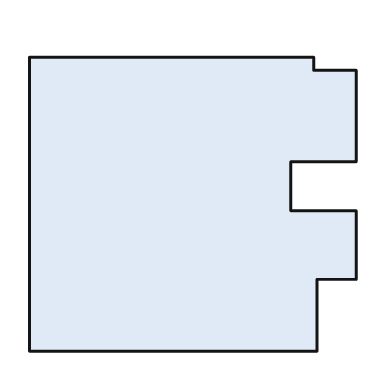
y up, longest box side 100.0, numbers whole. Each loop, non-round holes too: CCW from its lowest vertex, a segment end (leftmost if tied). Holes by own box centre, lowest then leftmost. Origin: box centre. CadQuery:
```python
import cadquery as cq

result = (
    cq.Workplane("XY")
    .moveTo(-50.0, -45.0)
    .lineTo(38.0, -45.0)
    .lineTo(38.0, -23.0)
    .lineTo(50.0, -23.0)
    .lineTo(50.0, -2.0)
    .lineTo(30.0, -2.0)
    .lineTo(30.0, 13.0)
    .lineTo(50.0, 13.0)
    .lineTo(50.0, 41.0)
    .lineTo(37.0, 41.0)
    .lineTo(37.0, 45.0)
    .lineTo(-50.0, 45.0)
    .close()
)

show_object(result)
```